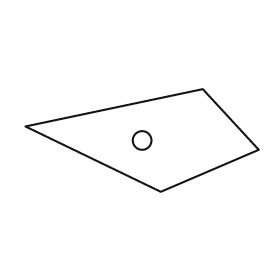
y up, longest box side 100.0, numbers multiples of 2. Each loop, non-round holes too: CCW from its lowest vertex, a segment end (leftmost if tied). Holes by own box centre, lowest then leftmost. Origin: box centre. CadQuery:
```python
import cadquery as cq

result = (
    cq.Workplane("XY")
    .moveTo(8.0, -22.0)
    .lineTo(50.0, -4.0)
    .lineTo(26.0, 22.0)
    .lineTo(-50.0, 6.0)
    .close()
    .moveTo(0.0, 0.0)
    .circle(4.0)
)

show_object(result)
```